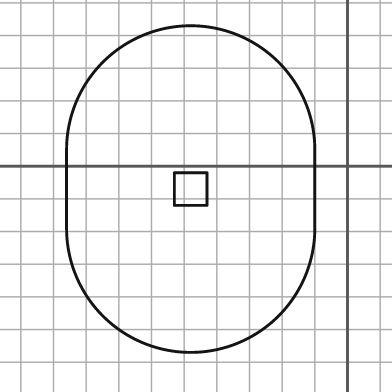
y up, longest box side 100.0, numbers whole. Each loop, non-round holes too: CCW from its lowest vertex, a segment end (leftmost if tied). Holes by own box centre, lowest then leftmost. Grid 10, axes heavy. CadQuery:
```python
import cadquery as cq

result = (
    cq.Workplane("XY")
    .moveTo(-86.0, -19.0)
    .threePointArc((-48.0, -57.0), (-10.0, -19.0))
    .lineTo(-10.0, 5.0)
    .threePointArc((-48.0, 43.0), (-86.0, 5.0))
    .close()
    .moveTo(-53.0, -12.0)
    .lineTo(-43.0, -12.0)
    .lineTo(-43.0, -2.0)
    .lineTo(-53.0, -2.0)
    .close()
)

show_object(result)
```